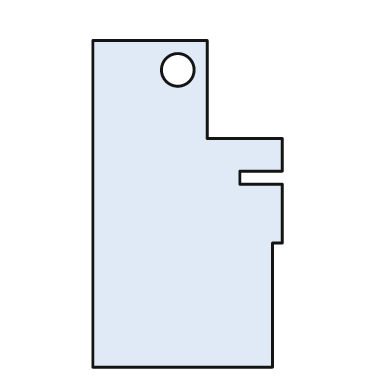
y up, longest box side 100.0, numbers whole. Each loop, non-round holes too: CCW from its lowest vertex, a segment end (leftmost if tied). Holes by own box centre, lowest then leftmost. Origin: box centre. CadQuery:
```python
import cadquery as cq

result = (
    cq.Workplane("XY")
    .moveTo(-29.0, -50.0)
    .lineTo(26.0, -50.0)
    .lineTo(26.0, -12.0)
    .lineTo(29.0, -12.0)
    .lineTo(29.0, 6.0)
    .lineTo(16.0, 6.0)
    .lineTo(16.0, 10.0)
    .lineTo(29.0, 10.0)
    .lineTo(29.0, 20.0)
    .lineTo(6.0, 20.0)
    .lineTo(6.0, 50.0)
    .lineTo(-29.0, 50.0)
    .close()
    .moveTo(-3.0, 41.0)
    .circle(5.0)
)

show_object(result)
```